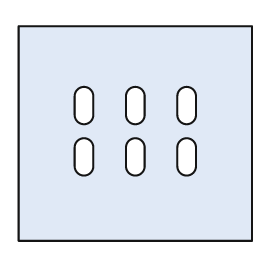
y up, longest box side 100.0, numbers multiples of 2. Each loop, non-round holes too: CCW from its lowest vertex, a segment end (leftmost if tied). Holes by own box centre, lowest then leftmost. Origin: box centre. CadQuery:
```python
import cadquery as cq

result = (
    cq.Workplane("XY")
    .moveTo(-50.0, -46.0)
    .lineTo(50.0, -46.0)
    .lineTo(50.0, 46.0)
    .lineTo(-50.0, 46.0)
    .close()
    .moveTo(-26.0, -14.0)
    .threePointArc((-22.0, -18.0), (-18.0, -14.0))
    .lineTo(-18.0, -6.0)
    .threePointArc((-22.0, -2.0), (-26.0, -6.0))
    .close()
    .moveTo(-4.0, -14.0)
    .threePointArc((0.0, -18.0), (4.0, -14.0))
    .lineTo(4.0, -6.0)
    .threePointArc((0.0, -2.0), (-4.0, -6.0))
    .close()
    .moveTo(18.0, -14.0)
    .threePointArc((22.0, -18.0), (26.0, -14.0))
    .lineTo(26.0, -6.0)
    .threePointArc((22.0, -2.0), (18.0, -6.0))
    .close()
    .moveTo(-26.0, 8.0)
    .threePointArc((-22.0, 4.0), (-18.0, 8.0))
    .lineTo(-18.0, 16.0)
    .threePointArc((-22.0, 20.0), (-26.0, 16.0))
    .close()
    .moveTo(-4.0, 8.0)
    .threePointArc((0.0, 4.0), (4.0, 8.0))
    .lineTo(4.0, 16.0)
    .threePointArc((0.0, 20.0), (-4.0, 16.0))
    .close()
    .moveTo(18.0, 8.0)
    .threePointArc((22.0, 4.0), (26.0, 8.0))
    .lineTo(26.0, 16.0)
    .threePointArc((22.0, 20.0), (18.0, 16.0))
    .close()
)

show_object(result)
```